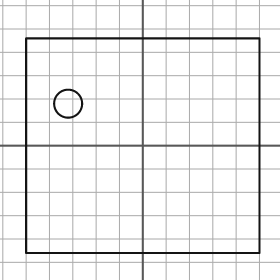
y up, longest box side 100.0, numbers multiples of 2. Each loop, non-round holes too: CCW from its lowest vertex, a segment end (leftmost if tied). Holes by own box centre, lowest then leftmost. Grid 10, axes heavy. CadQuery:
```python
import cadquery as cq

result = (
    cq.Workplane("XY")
    .moveTo(-50.0, -46.0)
    .lineTo(50.0, -46.0)
    .lineTo(50.0, 46.0)
    .lineTo(-50.0, 46.0)
    .close()
    .moveTo(-32.0, 18.0)
    .circle(6.0)
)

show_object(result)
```